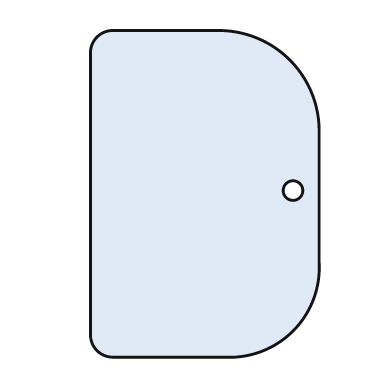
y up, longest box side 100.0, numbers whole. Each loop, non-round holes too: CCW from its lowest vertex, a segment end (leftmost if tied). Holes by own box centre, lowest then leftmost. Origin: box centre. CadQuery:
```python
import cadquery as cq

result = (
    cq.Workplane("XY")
    .moveTo(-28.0, -50.0)
    .lineTo(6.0, -50.0)
    .threePointArc((27.0, -42.0), (35.0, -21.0))
    .lineTo(35.0, 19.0)
    .threePointArc((26.0, 41.0), (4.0, 50.0))
    .lineTo(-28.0, 50.0)
    .threePointArc((-33.0, 48.0), (-35.0, 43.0))
    .lineTo(-35.0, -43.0)
    .threePointArc((-33.0, -48.0), (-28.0, -50.0))
    .close()
    .moveTo(27.0, 1.0)
    .circle(3.0)
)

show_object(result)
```